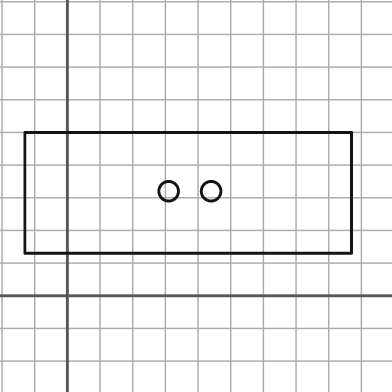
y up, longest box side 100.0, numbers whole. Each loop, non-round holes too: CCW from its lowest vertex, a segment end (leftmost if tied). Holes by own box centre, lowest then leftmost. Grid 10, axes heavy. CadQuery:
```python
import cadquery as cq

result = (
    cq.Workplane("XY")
    .moveTo(-13.0, 13.0)
    .lineTo(87.0, 13.0)
    .lineTo(87.0, 50.0)
    .lineTo(-13.0, 50.0)
    .close()
    .moveTo(31.0, 32.0)
    .circle(3.0)
    .moveTo(44.0, 32.0)
    .circle(3.0)
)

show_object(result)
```